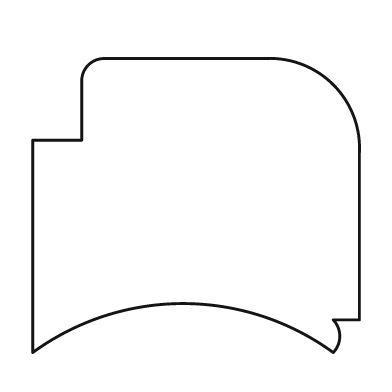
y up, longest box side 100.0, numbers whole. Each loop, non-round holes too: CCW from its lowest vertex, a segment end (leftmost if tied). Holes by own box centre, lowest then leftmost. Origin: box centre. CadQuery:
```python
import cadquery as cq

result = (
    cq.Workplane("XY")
    .moveTo(-50.0, -45.0)
    .threePointArc((-4.0, -30.0), (42.0, -45.0))
    .threePointArc((44.0, -40.0), (42.0, -35.0))
    .lineTo(50.0, -35.0)
    .lineTo(50.0, 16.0)
    .threePointArc((42.0, 37.0), (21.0, 45.0))
    .lineTo(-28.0, 45.0)
    .threePointArc((-33.0, 43.0), (-35.0, 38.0))
    .lineTo(-35.0, 20.0)
    .lineTo(-50.0, 20.0)
    .close()
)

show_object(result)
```